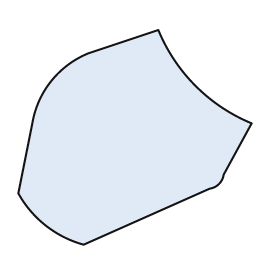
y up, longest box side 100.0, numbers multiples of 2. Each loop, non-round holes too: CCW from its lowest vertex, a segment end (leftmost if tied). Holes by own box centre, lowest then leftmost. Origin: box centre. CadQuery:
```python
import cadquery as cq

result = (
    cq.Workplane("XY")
    .moveTo(-22.0, -46.0)
    .lineTo(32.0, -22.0)
    .threePointArc((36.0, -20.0), (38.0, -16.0))
    .lineTo(50.0, 6.0)
    .threePointArc((26.0, 22.0), (10.0, 46.0))
    .lineTo(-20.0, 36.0)
    .threePointArc((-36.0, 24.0), (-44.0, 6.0))
    .lineTo(-50.0, -24.0)
    .threePointArc((-38.0, -38.0), (-22.0, -46.0))
    .close()
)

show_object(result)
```